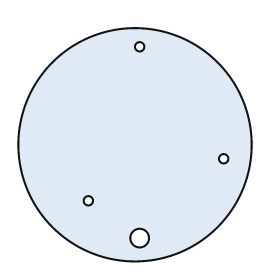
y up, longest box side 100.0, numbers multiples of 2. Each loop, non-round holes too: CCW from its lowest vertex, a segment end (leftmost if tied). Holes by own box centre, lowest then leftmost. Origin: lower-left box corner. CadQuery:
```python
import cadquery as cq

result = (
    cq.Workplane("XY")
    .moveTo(50.0, 50.0)
    .circle(50.0)
    .moveTo(52.0, 10.0)
    .circle(4.0)
    .moveTo(30.0, 26.0)
    .circle(2.0)
    .moveTo(88.0, 44.0)
    .circle(2.0)
    .moveTo(52.0, 92.0)
    .circle(2.0)
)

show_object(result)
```